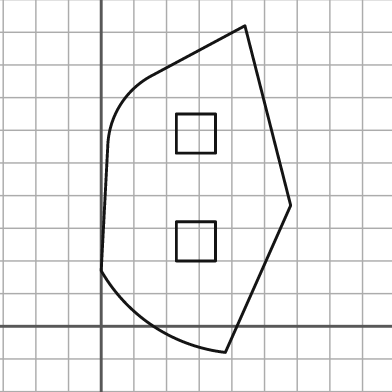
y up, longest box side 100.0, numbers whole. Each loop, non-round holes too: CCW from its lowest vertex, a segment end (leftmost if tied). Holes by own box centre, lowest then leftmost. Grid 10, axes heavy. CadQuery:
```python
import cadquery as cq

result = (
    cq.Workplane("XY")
    .moveTo(38.0, -8.0)
    .lineTo(58.0, 37.0)
    .lineTo(44.0, 92.0)
    .lineTo(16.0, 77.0)
    .threePointArc((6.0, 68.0), (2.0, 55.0))
    .lineTo(0.0, 17.0)
    .threePointArc((16.0, 0.0), (38.0, -8.0))
    .close()
    .moveTo(23.0, 20.0)
    .lineTo(35.0, 20.0)
    .lineTo(35.0, 32.0)
    .lineTo(23.0, 32.0)
    .close()
    .moveTo(23.0, 53.0)
    .lineTo(35.0, 53.0)
    .lineTo(35.0, 65.0)
    .lineTo(23.0, 65.0)
    .close()
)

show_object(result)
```